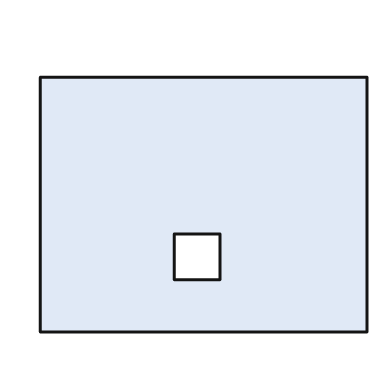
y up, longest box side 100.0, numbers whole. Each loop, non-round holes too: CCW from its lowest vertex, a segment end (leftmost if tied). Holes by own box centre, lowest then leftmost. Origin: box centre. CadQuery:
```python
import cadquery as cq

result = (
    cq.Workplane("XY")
    .moveTo(-50.0, -39.0)
    .lineTo(50.0, -39.0)
    .lineTo(50.0, 39.0)
    .lineTo(-50.0, 39.0)
    .close()
    .moveTo(-9.0, -23.0)
    .lineTo(5.0, -23.0)
    .lineTo(5.0, -9.0)
    .lineTo(-9.0, -9.0)
    .close()
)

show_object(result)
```